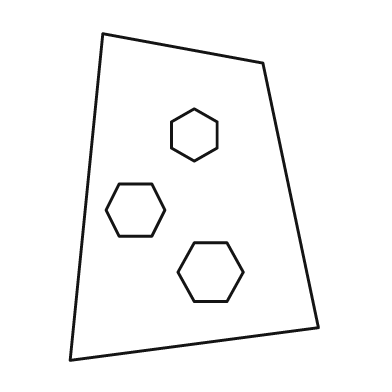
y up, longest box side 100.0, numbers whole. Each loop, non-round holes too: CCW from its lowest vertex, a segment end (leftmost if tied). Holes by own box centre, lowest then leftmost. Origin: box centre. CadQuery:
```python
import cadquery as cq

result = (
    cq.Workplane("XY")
    .moveTo(-38.0, -50.0)
    .lineTo(38.0, -40.0)
    .lineTo(21.0, 41.0)
    .lineTo(-28.0, 50.0)
    .close()
    .moveTo(0.0, -32.0)
    .lineTo(10.0, -32.0)
    .lineTo(15.0, -23.0)
    .lineTo(10.0, -14.0)
    .lineTo(0.0, -14.0)
    .lineTo(-5.0, -23.0)
    .close()
    .moveTo(-23.0, -12.0)
    .lineTo(-13.0, -12.0)
    .lineTo(-9.0, -4.0)
    .lineTo(-13.0, 4.0)
    .lineTo(-23.0, 4.0)
    .lineTo(-27.0, -4.0)
    .close()
    .moveTo(0.0, 11.0)
    .lineTo(7.0, 15.0)
    .lineTo(7.0, 23.0)
    .lineTo(0.0, 27.0)
    .lineTo(-7.0, 23.0)
    .lineTo(-7.0, 15.0)
    .close()
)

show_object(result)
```